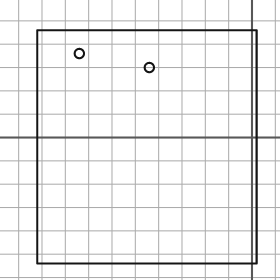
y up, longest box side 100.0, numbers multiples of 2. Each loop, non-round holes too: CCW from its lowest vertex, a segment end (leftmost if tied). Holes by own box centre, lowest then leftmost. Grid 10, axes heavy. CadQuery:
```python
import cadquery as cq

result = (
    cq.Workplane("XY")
    .moveTo(-92.0, -54.0)
    .lineTo(2.0, -54.0)
    .lineTo(2.0, 46.0)
    .lineTo(-92.0, 46.0)
    .close()
    .moveTo(-44.0, 30.0)
    .circle(2.0)
    .moveTo(-74.0, 36.0)
    .circle(2.0)
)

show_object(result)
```